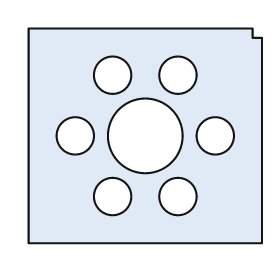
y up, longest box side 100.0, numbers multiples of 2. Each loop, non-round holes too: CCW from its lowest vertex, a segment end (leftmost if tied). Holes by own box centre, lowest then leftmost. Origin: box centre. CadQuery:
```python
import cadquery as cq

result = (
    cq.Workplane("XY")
    .moveTo(-50.0, -46.0)
    .lineTo(50.0, -46.0)
    .lineTo(50.0, 42.0)
    .lineTo(46.0, 42.0)
    .lineTo(46.0, 46.0)
    .lineTo(-50.0, 46.0)
    .close()
    .moveTo(-14.0, -26.0)
    .circle(8.0)
    .moveTo(14.0, -26.0)
    .circle(8.0)
    .moveTo(-30.0, 0.0)
    .circle(8.0)
    .moveTo(0.0, 0.0)
    .circle(16.0)
    .moveTo(30.0, 0.0)
    .circle(8.0)
    .moveTo(-14.0, 26.0)
    .circle(8.0)
    .moveTo(14.0, 26.0)
    .circle(8.0)
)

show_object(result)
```